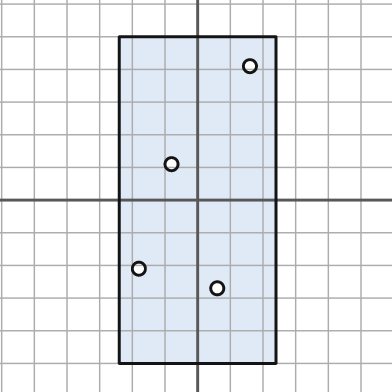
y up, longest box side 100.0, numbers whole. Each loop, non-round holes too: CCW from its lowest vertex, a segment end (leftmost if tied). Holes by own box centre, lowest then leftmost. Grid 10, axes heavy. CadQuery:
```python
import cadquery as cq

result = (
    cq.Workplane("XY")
    .moveTo(-24.0, -50.0)
    .lineTo(24.0, -50.0)
    .lineTo(24.0, 50.0)
    .lineTo(-24.0, 50.0)
    .close()
    .moveTo(6.0, -27.0)
    .circle(2.0)
    .moveTo(-18.0, -21.0)
    .circle(2.0)
    .moveTo(-8.0, 11.0)
    .circle(2.0)
    .moveTo(16.0, 41.0)
    .circle(2.0)
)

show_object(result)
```